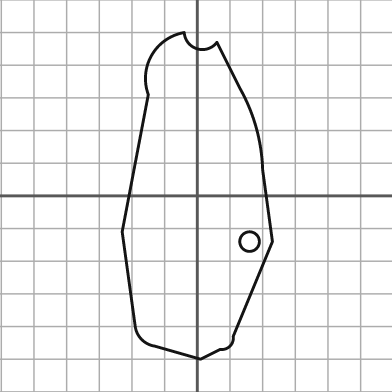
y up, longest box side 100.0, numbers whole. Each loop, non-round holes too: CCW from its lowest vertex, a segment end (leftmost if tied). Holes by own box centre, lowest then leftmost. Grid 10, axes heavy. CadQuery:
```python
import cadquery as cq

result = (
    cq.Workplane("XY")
    .moveTo(1.0, -50.0)
    .lineTo(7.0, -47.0)
    .threePointArc((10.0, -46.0), (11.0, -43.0))
    .lineTo(23.0, -14.0)
    .lineTo(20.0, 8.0)
    .threePointArc((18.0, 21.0), (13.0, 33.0))
    .lineTo(6.0, 47.0)
    .threePointArc((0.0, 45.0), (-4.0, 50.0))
    .threePointArc((-14.0, 43.0), (-15.0, 31.0))
    .lineTo(-23.0, -11.0)
    .lineTo(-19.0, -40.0)
    .threePointArc((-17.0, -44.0), (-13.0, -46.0))
    .close()
    .moveTo(16.0, -14.0)
    .circle(3.0)
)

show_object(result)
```